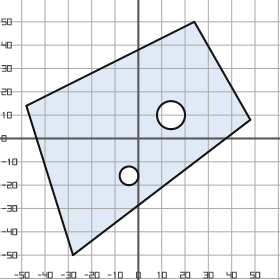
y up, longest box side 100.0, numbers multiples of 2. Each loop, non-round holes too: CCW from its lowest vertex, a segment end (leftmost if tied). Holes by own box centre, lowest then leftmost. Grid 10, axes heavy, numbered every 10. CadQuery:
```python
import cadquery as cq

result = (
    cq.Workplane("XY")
    .moveTo(-28.0, -50.0)
    .lineTo(48.0, 8.0)
    .lineTo(24.0, 50.0)
    .lineTo(-48.0, 14.0)
    .close()
    .moveTo(-4.0, -16.0)
    .circle(4.0)
    .moveTo(14.0, 10.0)
    .circle(6.0)
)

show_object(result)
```